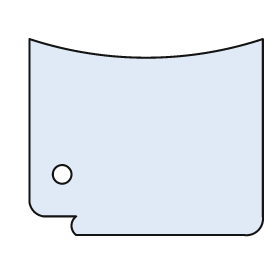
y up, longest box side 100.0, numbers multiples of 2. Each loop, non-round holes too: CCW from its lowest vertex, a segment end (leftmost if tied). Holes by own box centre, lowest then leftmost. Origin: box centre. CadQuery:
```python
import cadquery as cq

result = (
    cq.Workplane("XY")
    .moveTo(-30.0, -42.0)
    .lineTo(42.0, -42.0)
    .threePointArc((48.0, -40.0), (50.0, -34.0))
    .lineTo(50.0, 42.0)
    .threePointArc((0.0, 34.0), (-50.0, 42.0))
    .lineTo(-50.0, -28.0)
    .threePointArc((-48.0, -32.0), (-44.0, -34.0))
    .lineTo(-30.0, -34.0)
    .threePointArc((-32.0, -38.0), (-30.0, -42.0))
    .close()
    .moveTo(-36.0, -16.0)
    .circle(4.0)
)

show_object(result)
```